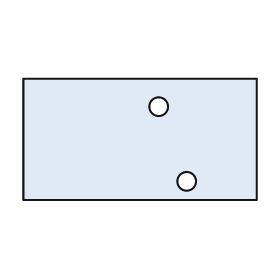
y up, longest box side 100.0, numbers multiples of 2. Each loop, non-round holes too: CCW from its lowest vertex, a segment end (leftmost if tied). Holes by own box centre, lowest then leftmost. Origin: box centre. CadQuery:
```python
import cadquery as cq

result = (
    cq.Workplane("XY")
    .moveTo(-50.0, -26.0)
    .lineTo(50.0, -26.0)
    .lineTo(50.0, 26.0)
    .lineTo(-50.0, 26.0)
    .close()
    .moveTo(20.0, -18.0)
    .circle(4.0)
    .moveTo(8.0, 14.0)
    .circle(4.0)
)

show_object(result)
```